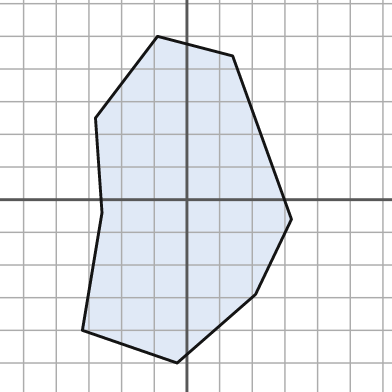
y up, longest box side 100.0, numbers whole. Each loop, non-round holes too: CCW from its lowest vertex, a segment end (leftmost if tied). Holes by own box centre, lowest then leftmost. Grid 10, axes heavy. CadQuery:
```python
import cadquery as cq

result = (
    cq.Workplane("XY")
    .moveTo(-3.0, -50.0)
    .lineTo(21.0, -29.0)
    .lineTo(32.0, -6.0)
    .lineTo(14.0, 44.0)
    .lineTo(-9.0, 50.0)
    .lineTo(-28.0, 25.0)
    .lineTo(-26.0, -4.0)
    .lineTo(-32.0, -40.0)
    .close()
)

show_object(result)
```